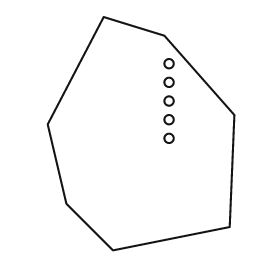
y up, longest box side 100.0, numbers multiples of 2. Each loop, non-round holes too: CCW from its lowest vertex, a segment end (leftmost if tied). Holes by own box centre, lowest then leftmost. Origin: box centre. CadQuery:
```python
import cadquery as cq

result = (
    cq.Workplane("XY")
    .moveTo(-12.0, -50.0)
    .lineTo(38.0, -40.0)
    .lineTo(40.0, 8.0)
    .lineTo(10.0, 42.0)
    .lineTo(-16.0, 50.0)
    .lineTo(-40.0, 4.0)
    .lineTo(-32.0, -30.0)
    .close()
    .moveTo(12.0, -2.0)
    .circle(2.0)
    .moveTo(12.0, 6.0)
    .circle(2.0)
    .moveTo(12.0, 14.0)
    .circle(2.0)
    .moveTo(12.0, 22.0)
    .circle(2.0)
    .moveTo(12.0, 30.0)
    .circle(2.0)
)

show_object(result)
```